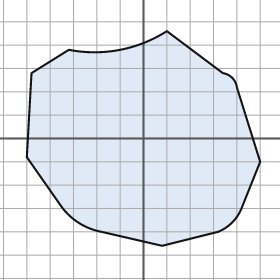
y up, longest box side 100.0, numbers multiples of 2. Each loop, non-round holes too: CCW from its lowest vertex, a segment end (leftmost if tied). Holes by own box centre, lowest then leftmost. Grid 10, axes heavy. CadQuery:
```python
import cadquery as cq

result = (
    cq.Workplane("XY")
    .moveTo(8.0, -46.0)
    .lineTo(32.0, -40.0)
    .threePointArc((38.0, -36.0), (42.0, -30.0))
    .lineTo(50.0, -10.0)
    .lineTo(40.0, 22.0)
    .threePointArc((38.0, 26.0), (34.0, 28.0))
    .lineTo(10.0, 46.0)
    .threePointArc((-10.0, 38.0), (-32.0, 38.0))
    .lineTo(-48.0, 28.0)
    .lineTo(-50.0, -8.0)
    .lineTo(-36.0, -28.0)
    .threePointArc((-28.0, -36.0), (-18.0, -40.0))
    .close()
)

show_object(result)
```